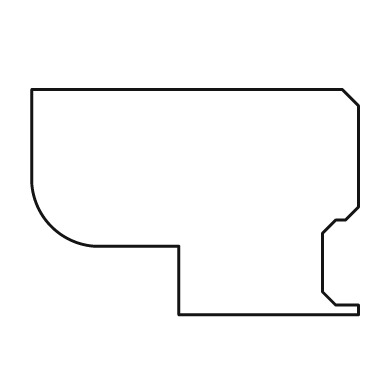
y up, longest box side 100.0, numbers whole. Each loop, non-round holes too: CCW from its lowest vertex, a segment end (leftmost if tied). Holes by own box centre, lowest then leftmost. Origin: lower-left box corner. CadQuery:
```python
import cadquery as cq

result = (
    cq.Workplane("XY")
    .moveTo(45.0, 0.0)
    .lineTo(100.0, 0.0)
    .lineTo(100.0, 3.0)
    .lineTo(93.0, 3.0)
    .lineTo(89.0, 7.0)
    .lineTo(89.0, 25.0)
    .lineTo(93.0, 29.0)
    .lineTo(96.0, 29.0)
    .lineTo(100.0, 33.0)
    .lineTo(100.0, 64.0)
    .lineTo(95.0, 69.0)
    .lineTo(0.0, 69.0)
    .lineTo(0.0, 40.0)
    .threePointArc((6.0, 27.0), (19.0, 21.0))
    .lineTo(45.0, 21.0)
    .close()
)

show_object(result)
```